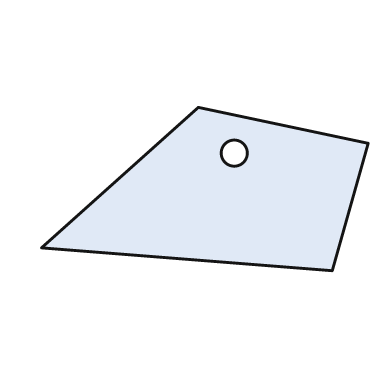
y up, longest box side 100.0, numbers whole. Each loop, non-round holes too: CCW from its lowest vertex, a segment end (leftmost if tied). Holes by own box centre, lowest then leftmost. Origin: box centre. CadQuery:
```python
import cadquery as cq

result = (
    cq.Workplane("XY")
    .moveTo(39.0, -25.0)
    .lineTo(50.0, 14.0)
    .lineTo(-2.0, 25.0)
    .lineTo(-50.0, -18.0)
    .close()
    .moveTo(9.0, 11.0)
    .circle(4.0)
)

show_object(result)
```